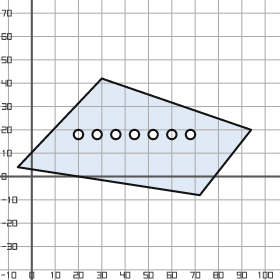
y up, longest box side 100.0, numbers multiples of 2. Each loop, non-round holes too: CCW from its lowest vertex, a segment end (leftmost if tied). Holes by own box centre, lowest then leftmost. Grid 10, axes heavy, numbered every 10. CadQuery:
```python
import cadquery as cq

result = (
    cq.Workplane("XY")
    .moveTo(72.0, -8.0)
    .lineTo(94.0, 20.0)
    .lineTo(30.0, 42.0)
    .lineTo(-6.0, 4.0)
    .close()
    .moveTo(20.0, 18.0)
    .circle(2.0)
    .moveTo(28.0, 18.0)
    .circle(2.0)
    .moveTo(36.0, 18.0)
    .circle(2.0)
    .moveTo(44.0, 18.0)
    .circle(2.0)
    .moveTo(52.0, 18.0)
    .circle(2.0)
    .moveTo(60.0, 18.0)
    .circle(2.0)
    .moveTo(68.0, 18.0)
    .circle(2.0)
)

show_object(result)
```